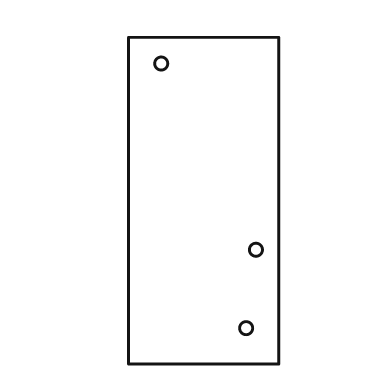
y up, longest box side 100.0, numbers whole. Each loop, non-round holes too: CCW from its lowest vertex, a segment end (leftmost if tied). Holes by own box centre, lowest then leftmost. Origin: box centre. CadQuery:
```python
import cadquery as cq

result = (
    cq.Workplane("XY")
    .moveTo(-23.0, -50.0)
    .lineTo(23.0, -50.0)
    .lineTo(23.0, 50.0)
    .lineTo(-23.0, 50.0)
    .close()
    .moveTo(13.0, -39.0)
    .circle(2.0)
    .moveTo(16.0, -15.0)
    .circle(2.0)
    .moveTo(-13.0, 42.0)
    .circle(2.0)
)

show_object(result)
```